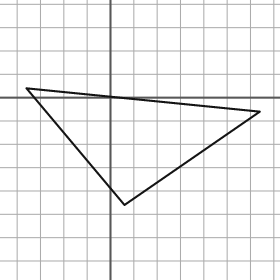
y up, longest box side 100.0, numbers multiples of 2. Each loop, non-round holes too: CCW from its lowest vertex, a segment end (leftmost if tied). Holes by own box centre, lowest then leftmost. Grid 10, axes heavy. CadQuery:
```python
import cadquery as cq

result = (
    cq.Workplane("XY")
    .moveTo(6.0, -46.0)
    .lineTo(64.0, -6.0)
    .lineTo(-36.0, 4.0)
    .close()
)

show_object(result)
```